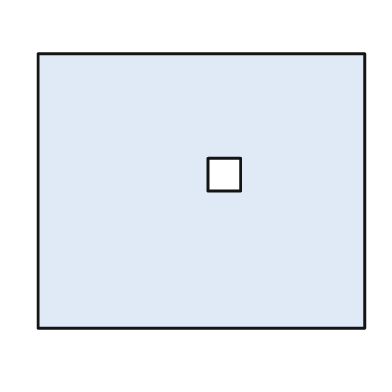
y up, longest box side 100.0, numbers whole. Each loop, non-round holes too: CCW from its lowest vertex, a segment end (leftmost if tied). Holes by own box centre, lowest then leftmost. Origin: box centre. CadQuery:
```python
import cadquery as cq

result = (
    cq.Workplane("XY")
    .moveTo(-50.0, -42.0)
    .lineTo(50.0, -42.0)
    .lineTo(50.0, 42.0)
    .lineTo(-50.0, 42.0)
    .close()
    .moveTo(2.0, 0.0)
    .lineTo(12.0, 0.0)
    .lineTo(12.0, 10.0)
    .lineTo(2.0, 10.0)
    .close()
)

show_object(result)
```